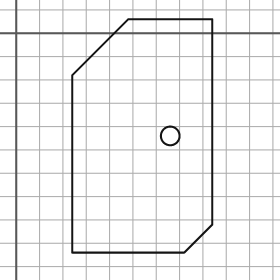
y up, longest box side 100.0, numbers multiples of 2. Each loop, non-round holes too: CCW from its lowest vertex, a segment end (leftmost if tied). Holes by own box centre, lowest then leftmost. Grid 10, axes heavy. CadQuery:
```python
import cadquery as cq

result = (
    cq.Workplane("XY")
    .moveTo(24.0, -94.0)
    .lineTo(72.0, -94.0)
    .lineTo(84.0, -82.0)
    .lineTo(84.0, 6.0)
    .lineTo(48.0, 6.0)
    .lineTo(24.0, -18.0)
    .close()
    .moveTo(66.0, -44.0)
    .circle(4.0)
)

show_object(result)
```